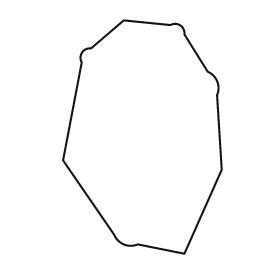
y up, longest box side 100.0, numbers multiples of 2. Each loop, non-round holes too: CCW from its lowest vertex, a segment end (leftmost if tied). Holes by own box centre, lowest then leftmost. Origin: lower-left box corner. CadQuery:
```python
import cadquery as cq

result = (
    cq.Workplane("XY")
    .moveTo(52.0, 0.0)
    .lineTo(68.0, 36.0)
    .lineTo(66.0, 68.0)
    .threePointArc((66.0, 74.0), (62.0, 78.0))
    .lineTo(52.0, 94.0)
    .threePointArc((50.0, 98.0), (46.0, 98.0))
    .lineTo(26.0, 100.0)
    .lineTo(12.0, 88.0)
    .threePointArc((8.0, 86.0), (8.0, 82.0))
    .lineTo(0.0, 40.0)
    .lineTo(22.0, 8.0)
    .threePointArc((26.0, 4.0), (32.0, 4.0))
    .close()
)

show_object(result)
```